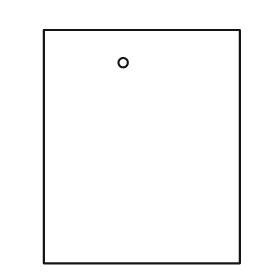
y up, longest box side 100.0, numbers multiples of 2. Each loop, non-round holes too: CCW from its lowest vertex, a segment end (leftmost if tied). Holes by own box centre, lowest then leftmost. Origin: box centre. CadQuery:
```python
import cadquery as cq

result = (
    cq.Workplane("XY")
    .moveTo(-42.0, -50.0)
    .lineTo(42.0, -50.0)
    .lineTo(42.0, 50.0)
    .lineTo(-42.0, 50.0)
    .close()
    .moveTo(-8.0, 36.0)
    .circle(2.0)
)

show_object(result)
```